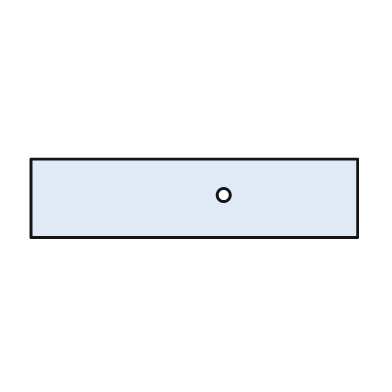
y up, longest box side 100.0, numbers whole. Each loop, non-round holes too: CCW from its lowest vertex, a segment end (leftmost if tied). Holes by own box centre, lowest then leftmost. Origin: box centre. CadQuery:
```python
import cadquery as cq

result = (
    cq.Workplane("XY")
    .moveTo(-50.0, -12.0)
    .lineTo(50.0, -12.0)
    .lineTo(50.0, 12.0)
    .lineTo(-50.0, 12.0)
    .close()
    .moveTo(9.0, 1.0)
    .circle(2.0)
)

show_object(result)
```